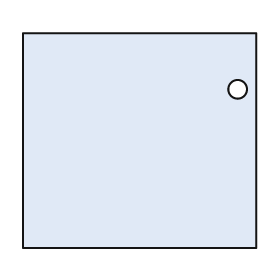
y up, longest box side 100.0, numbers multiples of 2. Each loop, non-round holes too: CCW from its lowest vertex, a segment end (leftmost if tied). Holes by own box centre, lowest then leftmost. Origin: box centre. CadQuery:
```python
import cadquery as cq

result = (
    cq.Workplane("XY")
    .moveTo(-50.0, -46.0)
    .lineTo(50.0, -46.0)
    .lineTo(50.0, 46.0)
    .lineTo(-50.0, 46.0)
    .close()
    .moveTo(42.0, 22.0)
    .circle(4.0)
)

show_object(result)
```